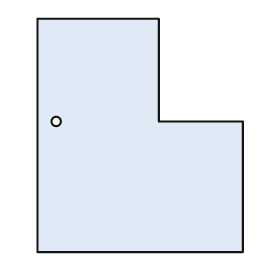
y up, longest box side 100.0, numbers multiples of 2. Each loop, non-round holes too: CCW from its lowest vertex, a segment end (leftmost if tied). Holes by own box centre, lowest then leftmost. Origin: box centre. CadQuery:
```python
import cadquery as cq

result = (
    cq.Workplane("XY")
    .moveTo(-44.0, -50.0)
    .lineTo(44.0, -50.0)
    .lineTo(44.0, 6.0)
    .lineTo(8.0, 6.0)
    .lineTo(8.0, 50.0)
    .lineTo(-44.0, 50.0)
    .close()
    .moveTo(-36.0, 6.0)
    .circle(2.0)
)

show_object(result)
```